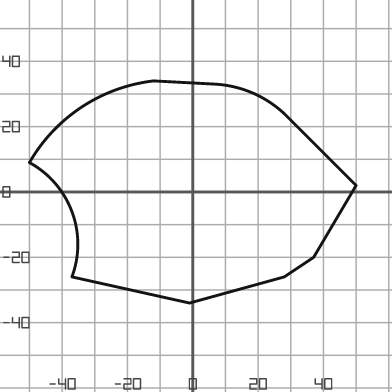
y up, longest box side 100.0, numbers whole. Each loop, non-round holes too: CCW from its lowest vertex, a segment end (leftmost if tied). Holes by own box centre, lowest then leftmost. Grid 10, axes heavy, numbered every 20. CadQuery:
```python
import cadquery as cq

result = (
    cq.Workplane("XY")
    .moveTo(-1.0, -34.0)
    .lineTo(28.0, -26.0)
    .lineTo(37.0, -20.0)
    .lineTo(50.0, 2.0)
    .lineTo(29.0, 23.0)
    .threePointArc((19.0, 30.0), (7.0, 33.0))
    .lineTo(-12.0, 34.0)
    .threePointArc((-34.0, 26.0), (-50.0, 9.0))
    .threePointArc((-37.0, -6.0), (-37.0, -26.0))
    .close()
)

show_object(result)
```